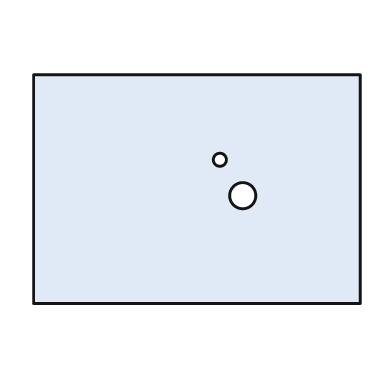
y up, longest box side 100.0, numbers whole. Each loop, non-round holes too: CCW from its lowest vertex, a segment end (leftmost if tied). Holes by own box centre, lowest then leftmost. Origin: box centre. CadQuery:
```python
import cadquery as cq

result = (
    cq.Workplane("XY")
    .moveTo(-50.0, -35.0)
    .lineTo(50.0, -35.0)
    .lineTo(50.0, 35.0)
    .lineTo(-50.0, 35.0)
    .close()
    .moveTo(14.0, -2.0)
    .circle(4.0)
    .moveTo(7.0, 9.0)
    .circle(2.0)
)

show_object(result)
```